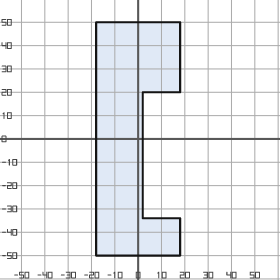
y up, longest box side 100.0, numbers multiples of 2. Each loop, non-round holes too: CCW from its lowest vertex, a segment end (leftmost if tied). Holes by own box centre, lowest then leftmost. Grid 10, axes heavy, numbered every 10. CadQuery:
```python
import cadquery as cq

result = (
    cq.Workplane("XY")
    .moveTo(-18.0, -50.0)
    .lineTo(18.0, -50.0)
    .lineTo(18.0, -34.0)
    .lineTo(2.0, -34.0)
    .lineTo(2.0, 20.0)
    .lineTo(18.0, 20.0)
    .lineTo(18.0, 50.0)
    .lineTo(-18.0, 50.0)
    .close()
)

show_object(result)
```